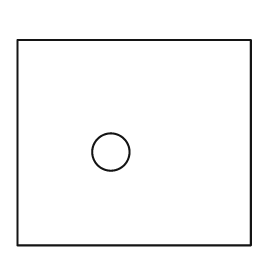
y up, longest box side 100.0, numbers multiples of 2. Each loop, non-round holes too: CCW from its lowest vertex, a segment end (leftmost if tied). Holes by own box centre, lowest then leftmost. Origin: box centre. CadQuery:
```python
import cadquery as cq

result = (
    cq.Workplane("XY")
    .moveTo(-50.0, -44.0)
    .lineTo(50.0, -44.0)
    .lineTo(50.0, 44.0)
    .lineTo(-50.0, 44.0)
    .close()
    .moveTo(-10.0, -4.0)
    .circle(8.0)
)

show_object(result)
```